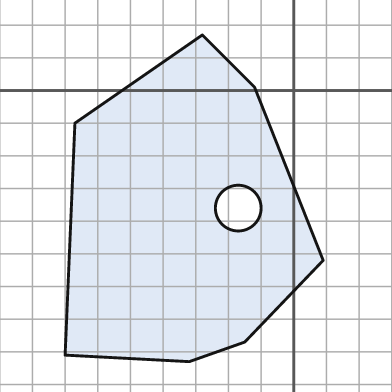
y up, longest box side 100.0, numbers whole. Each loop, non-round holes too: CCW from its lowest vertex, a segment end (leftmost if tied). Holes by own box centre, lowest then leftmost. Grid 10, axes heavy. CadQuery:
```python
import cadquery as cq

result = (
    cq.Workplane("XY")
    .moveTo(-32.0, -83.0)
    .lineTo(-15.0, -77.0)
    .lineTo(9.0, -52.0)
    .lineTo(-12.0, 1.0)
    .lineTo(-28.0, 17.0)
    .lineTo(-67.0, -10.0)
    .lineTo(-70.0, -81.0)
    .close()
    .moveTo(-17.0, -36.0)
    .circle(7.0)
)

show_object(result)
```